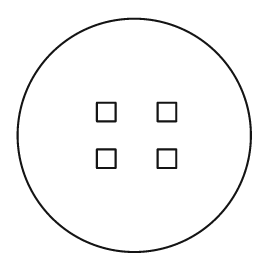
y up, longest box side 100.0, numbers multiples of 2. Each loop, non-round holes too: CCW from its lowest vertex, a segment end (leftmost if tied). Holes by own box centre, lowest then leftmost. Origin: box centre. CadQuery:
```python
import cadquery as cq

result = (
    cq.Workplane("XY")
    .moveTo(0.0, 0.0)
    .circle(50.0)
    .moveTo(-16.0, -14.0)
    .lineTo(-8.0, -14.0)
    .lineTo(-8.0, -6.0)
    .lineTo(-16.0, -6.0)
    .close()
    .moveTo(10.0, -14.0)
    .lineTo(18.0, -14.0)
    .lineTo(18.0, -6.0)
    .lineTo(10.0, -6.0)
    .close()
    .moveTo(-16.0, 6.0)
    .lineTo(-8.0, 6.0)
    .lineTo(-8.0, 14.0)
    .lineTo(-16.0, 14.0)
    .close()
    .moveTo(10.0, 6.0)
    .lineTo(18.0, 6.0)
    .lineTo(18.0, 14.0)
    .lineTo(10.0, 14.0)
    .close()
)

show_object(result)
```